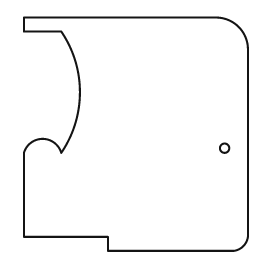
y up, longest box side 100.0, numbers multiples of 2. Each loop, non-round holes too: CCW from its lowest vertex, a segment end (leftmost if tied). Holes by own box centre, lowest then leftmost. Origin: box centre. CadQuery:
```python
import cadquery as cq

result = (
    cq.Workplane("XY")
    .moveTo(-12.0, -50.0)
    .lineTo(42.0, -50.0)
    .threePointArc((46.0, -48.0), (48.0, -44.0))
    .lineTo(48.0, 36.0)
    .threePointArc((44.0, 46.0), (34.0, 50.0))
    .lineTo(-48.0, 50.0)
    .lineTo(-48.0, 44.0)
    .lineTo(-32.0, 44.0)
    .threePointArc((-24.0, 18.0), (-32.0, -8.0))
    .threePointArc((-40.0, -2.0), (-48.0, -8.0))
    .lineTo(-48.0, -44.0)
    .lineTo(-12.0, -44.0)
    .close()
    .moveTo(38.0, -6.0)
    .circle(2.0)
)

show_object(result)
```